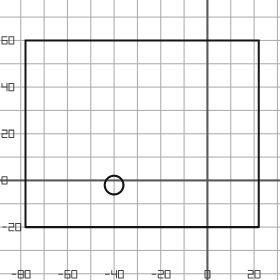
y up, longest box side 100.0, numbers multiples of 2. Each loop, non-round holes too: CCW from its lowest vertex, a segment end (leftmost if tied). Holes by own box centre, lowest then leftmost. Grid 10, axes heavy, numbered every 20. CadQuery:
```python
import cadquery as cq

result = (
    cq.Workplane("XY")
    .moveTo(-78.0, -20.0)
    .lineTo(22.0, -20.0)
    .lineTo(22.0, 60.0)
    .lineTo(-78.0, 60.0)
    .close()
    .moveTo(-40.0, -2.0)
    .circle(4.0)
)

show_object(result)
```